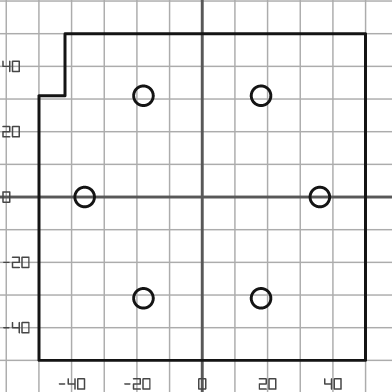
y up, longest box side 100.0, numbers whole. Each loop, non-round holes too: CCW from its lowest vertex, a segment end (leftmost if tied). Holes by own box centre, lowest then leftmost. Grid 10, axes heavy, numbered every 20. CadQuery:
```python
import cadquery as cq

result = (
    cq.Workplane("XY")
    .moveTo(-50.0, -50.0)
    .lineTo(50.0, -50.0)
    .lineTo(50.0, 50.0)
    .lineTo(-42.0, 50.0)
    .lineTo(-42.0, 31.0)
    .lineTo(-50.0, 31.0)
    .close()
    .moveTo(-18.0, -31.0)
    .circle(3.0)
    .moveTo(18.0, -31.0)
    .circle(3.0)
    .moveTo(-36.0, 0.0)
    .circle(3.0)
    .moveTo(36.0, 0.0)
    .circle(3.0)
    .moveTo(-18.0, 31.0)
    .circle(3.0)
    .moveTo(18.0, 31.0)
    .circle(3.0)
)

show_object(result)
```